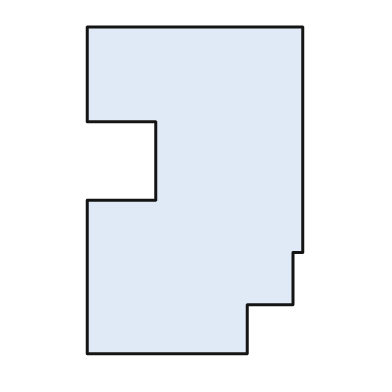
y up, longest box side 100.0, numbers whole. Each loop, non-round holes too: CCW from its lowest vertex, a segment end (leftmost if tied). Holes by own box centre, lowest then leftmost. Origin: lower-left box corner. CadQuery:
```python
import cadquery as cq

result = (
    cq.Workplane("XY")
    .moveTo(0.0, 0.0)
    .lineTo(49.0, 0.0)
    .lineTo(49.0, 15.0)
    .lineTo(63.0, 15.0)
    .lineTo(63.0, 31.0)
    .lineTo(66.0, 31.0)
    .lineTo(66.0, 100.0)
    .lineTo(0.0, 100.0)
    .lineTo(0.0, 71.0)
    .lineTo(21.0, 71.0)
    .lineTo(21.0, 47.0)
    .lineTo(0.0, 47.0)
    .close()
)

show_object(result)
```